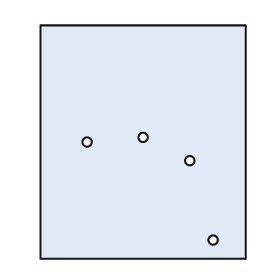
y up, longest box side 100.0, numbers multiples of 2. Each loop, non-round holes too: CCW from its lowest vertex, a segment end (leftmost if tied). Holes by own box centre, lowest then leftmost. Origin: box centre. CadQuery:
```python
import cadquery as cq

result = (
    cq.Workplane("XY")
    .moveTo(-44.0, -50.0)
    .lineTo(44.0, -50.0)
    .lineTo(44.0, 50.0)
    .lineTo(-44.0, 50.0)
    .close()
    .moveTo(30.0, -42.0)
    .circle(2.0)
    .moveTo(20.0, -8.0)
    .circle(2.0)
    .moveTo(-24.0, 0.0)
    .circle(2.0)
    .moveTo(0.0, 2.0)
    .circle(2.0)
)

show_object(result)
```